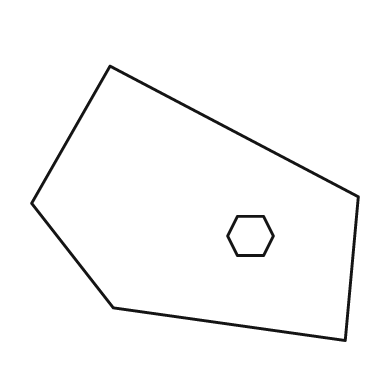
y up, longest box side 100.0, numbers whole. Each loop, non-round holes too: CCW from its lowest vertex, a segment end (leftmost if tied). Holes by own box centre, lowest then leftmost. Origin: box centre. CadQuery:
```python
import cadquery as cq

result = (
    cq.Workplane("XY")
    .moveTo(46.0, -42.0)
    .lineTo(50.0, 2.0)
    .lineTo(-26.0, 42.0)
    .lineTo(-50.0, 0.0)
    .lineTo(-25.0, -32.0)
    .close()
    .moveTo(13.0, -16.0)
    .lineTo(21.0, -16.0)
    .lineTo(24.0, -10.0)
    .lineTo(21.0, -4.0)
    .lineTo(13.0, -4.0)
    .lineTo(10.0, -10.0)
    .close()
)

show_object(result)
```